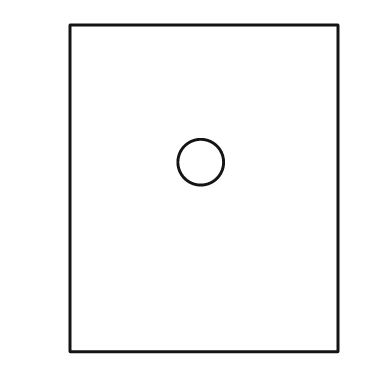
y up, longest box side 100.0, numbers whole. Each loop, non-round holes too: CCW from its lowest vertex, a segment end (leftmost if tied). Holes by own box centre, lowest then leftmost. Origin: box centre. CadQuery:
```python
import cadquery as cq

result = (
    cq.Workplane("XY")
    .moveTo(-41.0, -50.0)
    .lineTo(41.0, -50.0)
    .lineTo(41.0, 50.0)
    .lineTo(-41.0, 50.0)
    .close()
    .moveTo(-1.0, 8.0)
    .circle(7.0)
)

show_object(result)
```